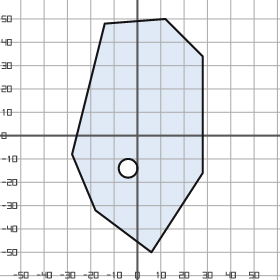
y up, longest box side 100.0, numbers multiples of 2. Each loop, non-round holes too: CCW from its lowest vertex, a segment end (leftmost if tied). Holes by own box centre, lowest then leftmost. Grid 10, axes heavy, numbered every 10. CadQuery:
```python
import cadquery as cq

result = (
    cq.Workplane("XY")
    .moveTo(6.0, -50.0)
    .lineTo(28.0, -16.0)
    .lineTo(28.0, 34.0)
    .lineTo(12.0, 50.0)
    .lineTo(-14.0, 48.0)
    .lineTo(-28.0, -8.0)
    .lineTo(-18.0, -32.0)
    .close()
    .moveTo(-4.0, -14.0)
    .circle(4.0)
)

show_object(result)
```